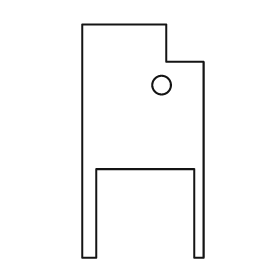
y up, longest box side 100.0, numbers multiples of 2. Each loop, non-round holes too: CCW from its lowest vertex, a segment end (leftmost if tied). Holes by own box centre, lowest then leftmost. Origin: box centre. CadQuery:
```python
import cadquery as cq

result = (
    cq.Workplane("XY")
    .moveTo(-26.0, -50.0)
    .lineTo(-20.0, -50.0)
    .lineTo(-20.0, -12.0)
    .lineTo(22.0, -12.0)
    .lineTo(22.0, -50.0)
    .lineTo(26.0, -50.0)
    .lineTo(26.0, 34.0)
    .lineTo(10.0, 34.0)
    .lineTo(10.0, 50.0)
    .lineTo(-26.0, 50.0)
    .close()
    .moveTo(8.0, 24.0)
    .circle(4.0)
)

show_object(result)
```